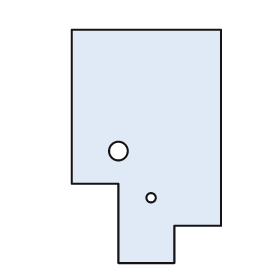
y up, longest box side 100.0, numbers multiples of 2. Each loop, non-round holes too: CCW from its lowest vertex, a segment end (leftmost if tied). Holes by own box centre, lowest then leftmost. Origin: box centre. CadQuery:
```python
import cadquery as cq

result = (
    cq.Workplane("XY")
    .moveTo(-12.0, -50.0)
    .lineTo(12.0, -50.0)
    .lineTo(12.0, -34.0)
    .lineTo(32.0, -34.0)
    .lineTo(32.0, 50.0)
    .lineTo(-32.0, 50.0)
    .lineTo(-32.0, -16.0)
    .lineTo(-12.0, -16.0)
    .close()
    .moveTo(2.0, -22.0)
    .circle(2.0)
    .moveTo(-12.0, -2.0)
    .circle(4.0)
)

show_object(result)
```